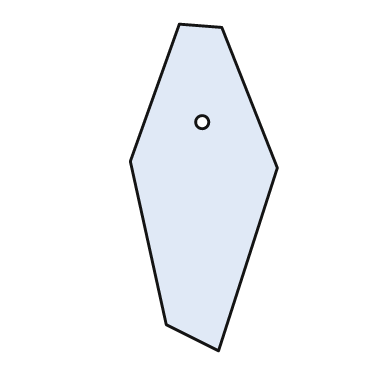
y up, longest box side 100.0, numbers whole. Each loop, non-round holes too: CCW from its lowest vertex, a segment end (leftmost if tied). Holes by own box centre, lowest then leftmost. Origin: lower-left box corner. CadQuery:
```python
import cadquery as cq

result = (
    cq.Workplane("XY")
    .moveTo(27.0, 0.0)
    .lineTo(45.0, 56.0)
    .lineTo(28.0, 99.0)
    .lineTo(15.0, 100.0)
    .lineTo(0.0, 58.0)
    .lineTo(11.0, 8.0)
    .close()
    .moveTo(22.0, 70.0)
    .circle(2.0)
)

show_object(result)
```